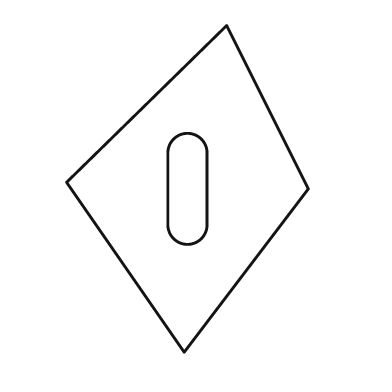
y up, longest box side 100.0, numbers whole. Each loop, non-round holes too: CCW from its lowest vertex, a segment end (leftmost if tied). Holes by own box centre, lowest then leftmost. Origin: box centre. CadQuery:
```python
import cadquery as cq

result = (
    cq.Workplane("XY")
    .moveTo(-1.0, -50.0)
    .lineTo(37.0, 0.0)
    .lineTo(12.0, 50.0)
    .lineTo(-37.0, 2.0)
    .close()
    .moveTo(-6.0, -11.0)
    .threePointArc((0.0, -17.0), (6.0, -11.0))
    .lineTo(6.0, 11.0)
    .threePointArc((0.0, 17.0), (-6.0, 11.0))
    .close()
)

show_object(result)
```